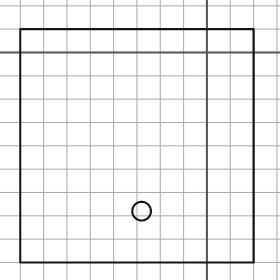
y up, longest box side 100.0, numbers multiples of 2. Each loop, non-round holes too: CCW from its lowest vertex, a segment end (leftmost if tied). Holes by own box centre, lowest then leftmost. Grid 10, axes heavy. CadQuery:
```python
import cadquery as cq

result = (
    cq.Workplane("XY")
    .moveTo(-80.0, -90.0)
    .lineTo(20.0, -90.0)
    .lineTo(20.0, 10.0)
    .lineTo(-80.0, 10.0)
    .close()
    .moveTo(-28.0, -68.0)
    .circle(4.0)
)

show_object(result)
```